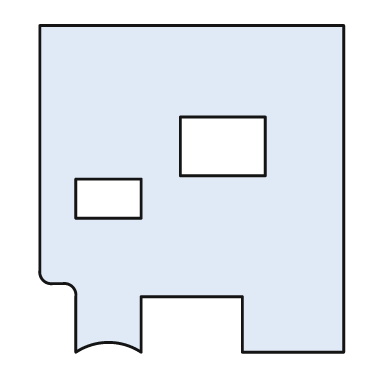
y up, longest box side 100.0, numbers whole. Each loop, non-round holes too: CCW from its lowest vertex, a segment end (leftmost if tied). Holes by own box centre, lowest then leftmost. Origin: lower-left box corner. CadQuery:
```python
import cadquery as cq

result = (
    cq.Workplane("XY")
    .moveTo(11.0, 0.0)
    .threePointArc((21.0, 3.0), (31.0, 0.0))
    .lineTo(31.0, 17.0)
    .lineTo(62.0, 17.0)
    .lineTo(62.0, 0.0)
    .lineTo(93.0, 0.0)
    .lineTo(93.0, 100.0)
    .lineTo(0.0, 100.0)
    .lineTo(0.0, 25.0)
    .threePointArc((1.0, 22.0), (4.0, 21.0))
    .lineTo(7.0, 21.0)
    .threePointArc((10.0, 20.0), (11.0, 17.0))
    .close()
    .moveTo(11.0, 41.0)
    .lineTo(31.0, 41.0)
    .lineTo(31.0, 53.0)
    .lineTo(11.0, 53.0)
    .close()
    .moveTo(43.0, 54.0)
    .lineTo(69.0, 54.0)
    .lineTo(69.0, 72.0)
    .lineTo(43.0, 72.0)
    .close()
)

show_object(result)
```